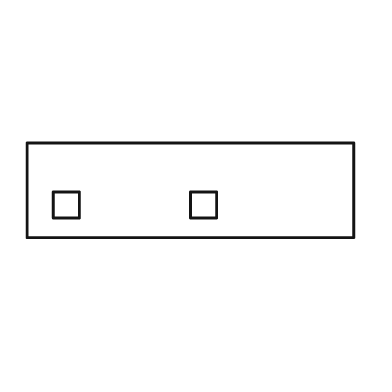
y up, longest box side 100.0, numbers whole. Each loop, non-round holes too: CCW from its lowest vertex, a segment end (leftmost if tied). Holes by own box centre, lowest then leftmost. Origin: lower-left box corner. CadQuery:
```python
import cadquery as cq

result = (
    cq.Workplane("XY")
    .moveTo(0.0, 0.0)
    .lineTo(100.0, 0.0)
    .lineTo(100.0, 29.0)
    .lineTo(0.0, 29.0)
    .close()
    .moveTo(8.0, 6.0)
    .lineTo(16.0, 6.0)
    .lineTo(16.0, 14.0)
    .lineTo(8.0, 14.0)
    .close()
    .moveTo(50.0, 6.0)
    .lineTo(58.0, 6.0)
    .lineTo(58.0, 14.0)
    .lineTo(50.0, 14.0)
    .close()
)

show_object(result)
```